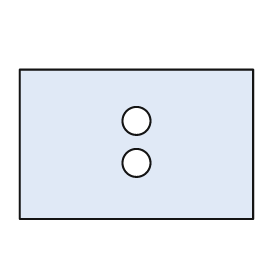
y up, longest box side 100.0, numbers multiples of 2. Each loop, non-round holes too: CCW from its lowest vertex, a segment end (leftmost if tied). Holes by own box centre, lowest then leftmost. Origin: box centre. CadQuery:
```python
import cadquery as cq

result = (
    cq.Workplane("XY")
    .moveTo(-50.0, -32.0)
    .lineTo(50.0, -32.0)
    .lineTo(50.0, 32.0)
    .lineTo(-50.0, 32.0)
    .close()
    .moveTo(0.0, -8.0)
    .circle(6.0)
    .moveTo(0.0, 10.0)
    .circle(6.0)
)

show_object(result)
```